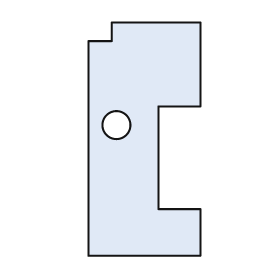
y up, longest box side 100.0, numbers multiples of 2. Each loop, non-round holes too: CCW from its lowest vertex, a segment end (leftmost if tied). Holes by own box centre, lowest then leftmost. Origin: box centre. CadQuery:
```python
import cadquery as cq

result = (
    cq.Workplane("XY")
    .moveTo(-24.0, -50.0)
    .lineTo(24.0, -50.0)
    .lineTo(24.0, -30.0)
    .lineTo(6.0, -30.0)
    .lineTo(6.0, 14.0)
    .lineTo(24.0, 14.0)
    .lineTo(24.0, 50.0)
    .lineTo(-14.0, 50.0)
    .lineTo(-14.0, 42.0)
    .lineTo(-24.0, 42.0)
    .close()
    .moveTo(-12.0, 6.0)
    .circle(6.0)
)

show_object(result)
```